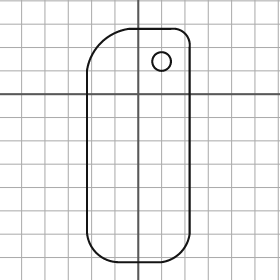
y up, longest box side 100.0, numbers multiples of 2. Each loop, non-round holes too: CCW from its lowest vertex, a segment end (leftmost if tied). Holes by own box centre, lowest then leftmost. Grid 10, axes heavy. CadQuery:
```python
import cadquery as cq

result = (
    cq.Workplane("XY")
    .moveTo(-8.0, -72.0)
    .lineTo(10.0, -72.0)
    .threePointArc((18.0, -68.0), (22.0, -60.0))
    .lineTo(22.0, 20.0)
    .threePointArc((20.0, 26.0), (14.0, 28.0))
    .lineTo(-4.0, 28.0)
    .threePointArc((-16.0, 22.0), (-22.0, 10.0))
    .lineTo(-22.0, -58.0)
    .threePointArc((-18.0, -68.0), (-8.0, -72.0))
    .close()
    .moveTo(10.0, 14.0)
    .circle(4.0)
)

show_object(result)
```